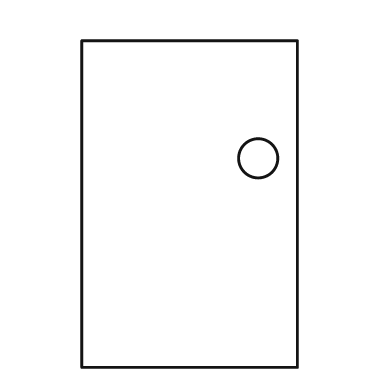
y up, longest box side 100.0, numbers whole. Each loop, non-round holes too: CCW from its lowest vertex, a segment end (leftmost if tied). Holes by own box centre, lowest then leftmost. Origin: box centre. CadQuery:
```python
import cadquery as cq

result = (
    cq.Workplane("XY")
    .moveTo(-33.0, -50.0)
    .lineTo(33.0, -50.0)
    .lineTo(33.0, 50.0)
    .lineTo(-33.0, 50.0)
    .close()
    .moveTo(21.0, 14.0)
    .circle(6.0)
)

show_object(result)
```